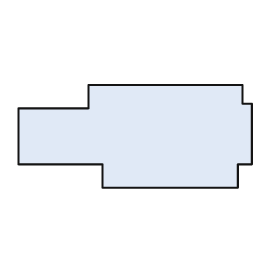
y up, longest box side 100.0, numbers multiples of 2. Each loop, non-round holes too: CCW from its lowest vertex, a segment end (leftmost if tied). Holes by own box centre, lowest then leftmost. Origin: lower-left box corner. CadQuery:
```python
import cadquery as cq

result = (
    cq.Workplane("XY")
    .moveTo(36.0, 0.0)
    .lineTo(94.0, 0.0)
    .lineTo(94.0, 10.0)
    .lineTo(100.0, 10.0)
    .lineTo(100.0, 36.0)
    .lineTo(96.0, 36.0)
    .lineTo(96.0, 44.0)
    .lineTo(30.0, 44.0)
    .lineTo(30.0, 34.0)
    .lineTo(0.0, 34.0)
    .lineTo(0.0, 10.0)
    .lineTo(36.0, 10.0)
    .close()
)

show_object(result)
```